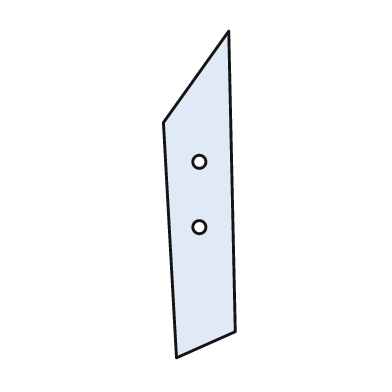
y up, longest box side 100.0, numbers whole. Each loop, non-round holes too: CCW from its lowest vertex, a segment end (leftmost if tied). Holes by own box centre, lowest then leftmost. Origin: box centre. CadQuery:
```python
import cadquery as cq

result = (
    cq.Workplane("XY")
    .moveTo(-7.0, -50.0)
    .lineTo(11.0, -42.0)
    .lineTo(9.0, 50.0)
    .lineTo(-11.0, 22.0)
    .close()
    .moveTo(0.0, -10.0)
    .circle(2.0)
    .moveTo(0.0, 10.0)
    .circle(2.0)
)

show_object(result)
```